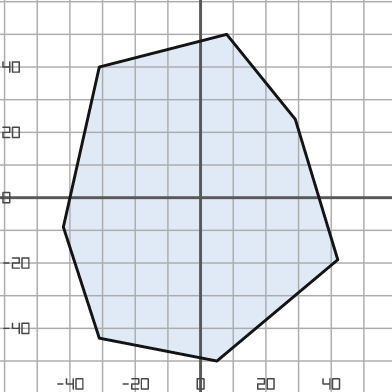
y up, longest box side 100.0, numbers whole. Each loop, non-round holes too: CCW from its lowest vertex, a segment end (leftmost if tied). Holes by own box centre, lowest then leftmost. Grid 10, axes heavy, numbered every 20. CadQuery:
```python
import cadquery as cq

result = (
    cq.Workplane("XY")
    .moveTo(5.0, -50.0)
    .lineTo(42.0, -19.0)
    .lineTo(29.0, 24.0)
    .lineTo(8.0, 50.0)
    .lineTo(-31.0, 40.0)
    .lineTo(-42.0, -9.0)
    .lineTo(-31.0, -43.0)
    .close()
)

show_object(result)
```